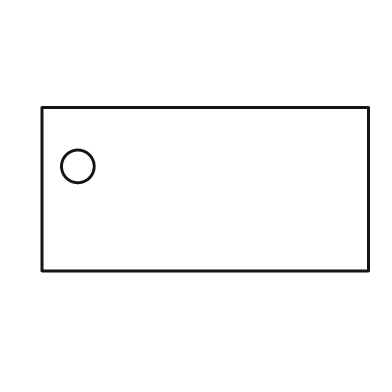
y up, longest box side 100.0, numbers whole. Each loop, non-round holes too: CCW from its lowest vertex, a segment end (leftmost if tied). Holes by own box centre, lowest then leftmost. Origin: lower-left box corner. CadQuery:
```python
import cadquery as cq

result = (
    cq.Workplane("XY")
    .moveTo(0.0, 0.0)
    .lineTo(100.0, 0.0)
    .lineTo(100.0, 50.0)
    .lineTo(0.0, 50.0)
    .close()
    .moveTo(11.0, 32.0)
    .circle(5.0)
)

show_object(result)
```